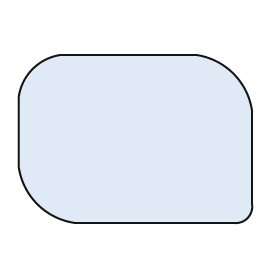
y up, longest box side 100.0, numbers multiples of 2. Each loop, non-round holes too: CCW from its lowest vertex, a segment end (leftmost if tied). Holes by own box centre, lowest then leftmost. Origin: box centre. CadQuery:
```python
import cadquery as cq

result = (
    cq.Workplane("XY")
    .moveTo(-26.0, -36.0)
    .lineTo(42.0, -36.0)
    .threePointArc((48.0, -34.0), (50.0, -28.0))
    .lineTo(50.0, 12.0)
    .threePointArc((42.0, 28.0), (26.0, 36.0))
    .lineTo(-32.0, 36.0)
    .threePointArc((-44.0, 30.0), (-50.0, 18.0))
    .lineTo(-50.0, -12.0)
    .threePointArc((-42.0, -28.0), (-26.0, -36.0))
    .close()
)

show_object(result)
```